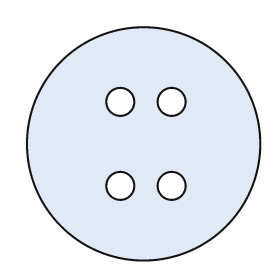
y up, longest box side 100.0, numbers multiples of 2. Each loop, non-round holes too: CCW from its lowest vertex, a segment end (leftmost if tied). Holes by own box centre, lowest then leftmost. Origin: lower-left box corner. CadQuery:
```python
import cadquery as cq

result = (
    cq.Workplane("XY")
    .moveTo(50.0, 50.0)
    .circle(50.0)
    .moveTo(40.0, 32.0)
    .circle(6.0)
    .moveTo(62.0, 32.0)
    .circle(6.0)
    .moveTo(40.0, 68.0)
    .circle(6.0)
    .moveTo(62.0, 68.0)
    .circle(6.0)
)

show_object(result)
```